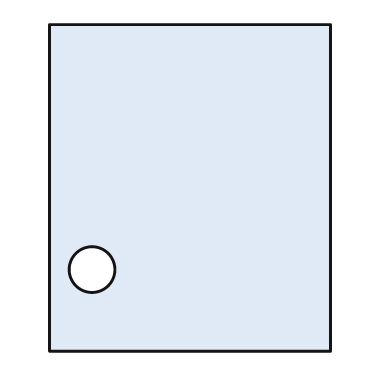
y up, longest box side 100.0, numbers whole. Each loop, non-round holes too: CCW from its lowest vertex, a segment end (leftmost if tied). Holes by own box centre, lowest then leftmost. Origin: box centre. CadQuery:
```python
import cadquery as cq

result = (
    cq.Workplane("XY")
    .moveTo(-43.0, -50.0)
    .lineTo(43.0, -50.0)
    .lineTo(43.0, 50.0)
    .lineTo(-43.0, 50.0)
    .close()
    .moveTo(-30.0, -25.0)
    .circle(7.0)
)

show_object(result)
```